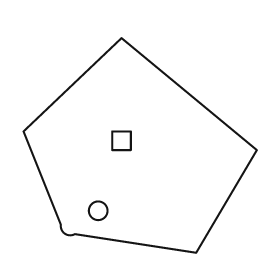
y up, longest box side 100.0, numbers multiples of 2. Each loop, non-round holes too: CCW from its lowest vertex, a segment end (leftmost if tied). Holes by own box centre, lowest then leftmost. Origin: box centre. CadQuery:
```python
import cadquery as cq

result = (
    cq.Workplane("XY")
    .moveTo(24.0, -46.0)
    .lineTo(50.0, -2.0)
    .lineTo(-8.0, 46.0)
    .lineTo(-50.0, 6.0)
    .lineTo(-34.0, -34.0)
    .threePointArc((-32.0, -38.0), (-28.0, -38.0))
    .close()
    .moveTo(-18.0, -28.0)
    .circle(4.0)
    .moveTo(-12.0, -2.0)
    .lineTo(-4.0, -2.0)
    .lineTo(-4.0, 6.0)
    .lineTo(-12.0, 6.0)
    .close()
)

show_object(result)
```